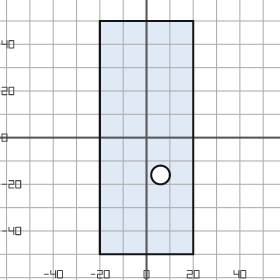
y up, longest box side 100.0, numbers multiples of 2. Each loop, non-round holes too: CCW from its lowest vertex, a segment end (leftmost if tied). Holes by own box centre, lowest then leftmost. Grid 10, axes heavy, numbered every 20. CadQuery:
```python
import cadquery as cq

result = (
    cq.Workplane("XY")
    .moveTo(-20.0, -50.0)
    .lineTo(20.0, -50.0)
    .lineTo(20.0, 50.0)
    .lineTo(-20.0, 50.0)
    .close()
    .moveTo(6.0, -16.0)
    .circle(4.0)
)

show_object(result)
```